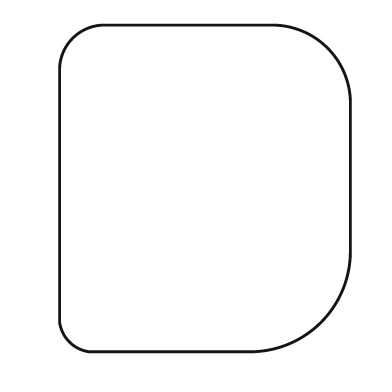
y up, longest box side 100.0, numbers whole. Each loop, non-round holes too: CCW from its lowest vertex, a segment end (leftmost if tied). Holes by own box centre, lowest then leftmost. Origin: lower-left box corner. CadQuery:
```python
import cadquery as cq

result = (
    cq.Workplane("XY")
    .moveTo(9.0, 0.0)
    .lineTo(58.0, 0.0)
    .threePointArc((80.0, 9.0), (89.0, 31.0))
    .lineTo(89.0, 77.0)
    .threePointArc((82.0, 93.0), (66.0, 100.0))
    .lineTo(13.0, 100.0)
    .threePointArc((4.0, 96.0), (0.0, 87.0))
    .lineTo(0.0, 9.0)
    .threePointArc((3.0, 3.0), (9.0, 0.0))
    .close()
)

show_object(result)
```